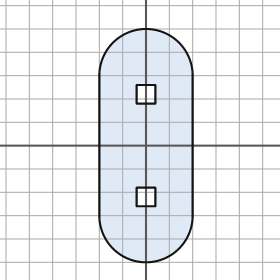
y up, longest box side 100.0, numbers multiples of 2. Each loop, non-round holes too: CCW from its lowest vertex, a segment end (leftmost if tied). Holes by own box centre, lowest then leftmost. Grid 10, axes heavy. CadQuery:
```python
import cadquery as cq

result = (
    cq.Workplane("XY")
    .moveTo(-20.0, -30.0)
    .threePointArc((0.0, -50.0), (20.0, -30.0))
    .lineTo(20.0, 30.0)
    .threePointArc((0.0, 50.0), (-20.0, 30.0))
    .close()
    .moveTo(-4.0, -26.0)
    .lineTo(4.0, -26.0)
    .lineTo(4.0, -18.0)
    .lineTo(-4.0, -18.0)
    .close()
    .moveTo(-4.0, 18.0)
    .lineTo(4.0, 18.0)
    .lineTo(4.0, 26.0)
    .lineTo(-4.0, 26.0)
    .close()
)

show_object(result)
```